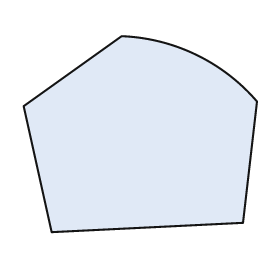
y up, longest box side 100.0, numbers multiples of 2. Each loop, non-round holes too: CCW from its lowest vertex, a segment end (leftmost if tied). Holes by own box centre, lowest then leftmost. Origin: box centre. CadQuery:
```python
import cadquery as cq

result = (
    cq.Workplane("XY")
    .moveTo(-38.0, -42.0)
    .lineTo(44.0, -38.0)
    .lineTo(50.0, 14.0)
    .threePointArc((24.0, 34.0), (-8.0, 42.0))
    .lineTo(-50.0, 12.0)
    .close()
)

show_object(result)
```